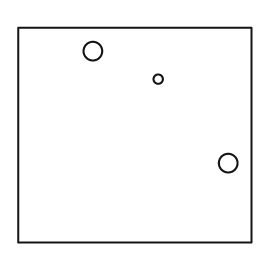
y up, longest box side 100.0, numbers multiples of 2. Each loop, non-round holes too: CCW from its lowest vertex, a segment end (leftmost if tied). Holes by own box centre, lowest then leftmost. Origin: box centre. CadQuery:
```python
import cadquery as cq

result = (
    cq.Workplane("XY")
    .moveTo(-50.0, -46.0)
    .lineTo(50.0, -46.0)
    .lineTo(50.0, 46.0)
    .lineTo(-50.0, 46.0)
    .close()
    .moveTo(40.0, -12.0)
    .circle(4.0)
    .moveTo(10.0, 24.0)
    .circle(2.0)
    .moveTo(-18.0, 36.0)
    .circle(4.0)
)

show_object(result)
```